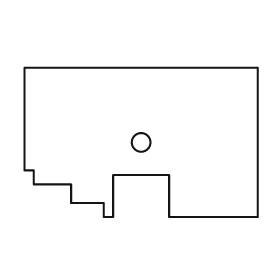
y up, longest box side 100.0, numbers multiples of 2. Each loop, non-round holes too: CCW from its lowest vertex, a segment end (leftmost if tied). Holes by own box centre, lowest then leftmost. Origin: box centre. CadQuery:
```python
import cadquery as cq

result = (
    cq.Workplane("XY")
    .moveTo(-16.0, -32.0)
    .lineTo(-12.0, -32.0)
    .lineTo(-12.0, -14.0)
    .lineTo(12.0, -14.0)
    .lineTo(12.0, -32.0)
    .lineTo(50.0, -32.0)
    .lineTo(50.0, 32.0)
    .lineTo(-50.0, 32.0)
    .lineTo(-50.0, -12.0)
    .lineTo(-46.0, -12.0)
    .lineTo(-46.0, -18.0)
    .lineTo(-30.0, -18.0)
    .lineTo(-30.0, -26.0)
    .lineTo(-16.0, -26.0)
    .close()
    .moveTo(0.0, 0.0)
    .circle(4.0)
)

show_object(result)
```